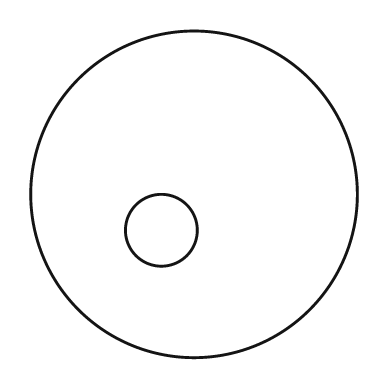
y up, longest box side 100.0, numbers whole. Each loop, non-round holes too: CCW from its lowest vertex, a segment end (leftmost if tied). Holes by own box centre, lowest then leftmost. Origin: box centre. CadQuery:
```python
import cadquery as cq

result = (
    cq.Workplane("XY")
    .moveTo(0.0, 0.0)
    .circle(50.0)
    .moveTo(-10.0, -11.0)
    .circle(11.0)
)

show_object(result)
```